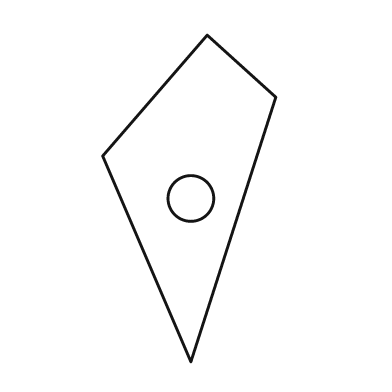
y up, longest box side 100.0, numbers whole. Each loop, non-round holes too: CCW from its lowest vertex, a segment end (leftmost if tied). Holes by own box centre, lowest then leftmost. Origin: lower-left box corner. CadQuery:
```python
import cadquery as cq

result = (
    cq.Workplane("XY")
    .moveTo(27.0, 0.0)
    .lineTo(53.0, 81.0)
    .lineTo(32.0, 100.0)
    .lineTo(0.0, 63.0)
    .close()
    .moveTo(27.0, 50.0)
    .circle(7.0)
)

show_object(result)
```